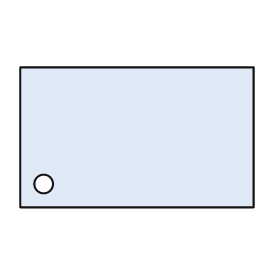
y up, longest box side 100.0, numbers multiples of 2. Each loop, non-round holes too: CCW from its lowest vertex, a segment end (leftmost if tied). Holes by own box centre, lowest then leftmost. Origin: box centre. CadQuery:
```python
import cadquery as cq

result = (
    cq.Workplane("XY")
    .moveTo(-50.0, -30.0)
    .lineTo(50.0, -30.0)
    .lineTo(50.0, 30.0)
    .lineTo(-50.0, 30.0)
    .close()
    .moveTo(-40.0, -20.0)
    .circle(4.0)
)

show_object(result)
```